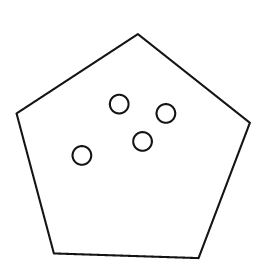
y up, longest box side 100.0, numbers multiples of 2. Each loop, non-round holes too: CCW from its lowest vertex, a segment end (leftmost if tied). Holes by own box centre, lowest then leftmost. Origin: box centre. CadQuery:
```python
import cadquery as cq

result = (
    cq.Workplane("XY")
    .moveTo(28.0, -48.0)
    .lineTo(50.0, 10.0)
    .lineTo(2.0, 48.0)
    .lineTo(-50.0, 14.0)
    .lineTo(-34.0, -46.0)
    .close()
    .moveTo(-22.0, -4.0)
    .circle(4.0)
    .moveTo(4.0, 2.0)
    .circle(4.0)
    .moveTo(14.0, 14.0)
    .circle(4.0)
    .moveTo(-6.0, 18.0)
    .circle(4.0)
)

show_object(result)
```